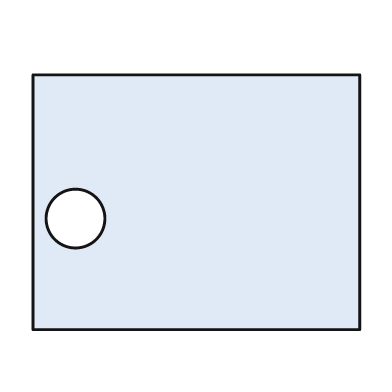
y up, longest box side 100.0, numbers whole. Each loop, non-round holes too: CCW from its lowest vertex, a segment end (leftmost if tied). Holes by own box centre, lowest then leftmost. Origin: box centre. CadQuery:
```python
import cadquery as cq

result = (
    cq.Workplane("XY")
    .moveTo(-50.0, -39.0)
    .lineTo(50.0, -39.0)
    .lineTo(50.0, 39.0)
    .lineTo(-50.0, 39.0)
    .close()
    .moveTo(-37.0, -5.0)
    .circle(9.0)
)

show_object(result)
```